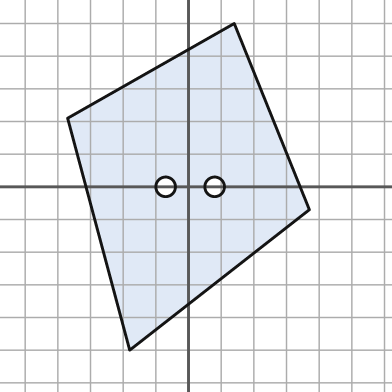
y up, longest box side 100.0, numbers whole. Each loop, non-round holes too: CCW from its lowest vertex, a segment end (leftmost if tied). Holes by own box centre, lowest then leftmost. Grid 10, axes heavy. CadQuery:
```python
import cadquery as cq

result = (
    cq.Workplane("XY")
    .moveTo(-18.0, -50.0)
    .lineTo(37.0, -7.0)
    .lineTo(14.0, 50.0)
    .lineTo(-37.0, 21.0)
    .close()
    .moveTo(-7.0, 0.0)
    .circle(3.0)
    .moveTo(8.0, 0.0)
    .circle(3.0)
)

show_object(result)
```